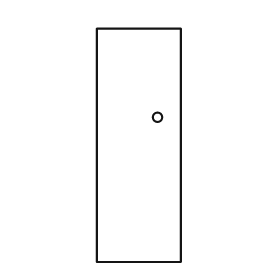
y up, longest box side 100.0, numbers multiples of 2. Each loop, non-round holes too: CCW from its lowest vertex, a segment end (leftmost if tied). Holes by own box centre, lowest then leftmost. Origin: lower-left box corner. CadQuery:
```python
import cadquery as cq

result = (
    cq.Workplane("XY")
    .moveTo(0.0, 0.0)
    .lineTo(36.0, 0.0)
    .lineTo(36.0, 100.0)
    .lineTo(0.0, 100.0)
    .close()
    .moveTo(26.0, 62.0)
    .circle(2.0)
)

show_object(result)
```